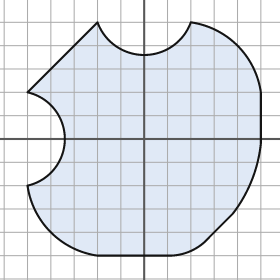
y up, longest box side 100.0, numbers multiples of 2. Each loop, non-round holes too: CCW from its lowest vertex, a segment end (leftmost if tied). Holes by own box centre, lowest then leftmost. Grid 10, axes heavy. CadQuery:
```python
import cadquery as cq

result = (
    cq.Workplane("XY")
    .moveTo(-20.0, -50.0)
    .lineTo(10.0, -50.0)
    .threePointArc((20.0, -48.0), (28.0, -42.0))
    .lineTo(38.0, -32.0)
    .threePointArc((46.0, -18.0), (50.0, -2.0))
    .lineTo(50.0, 20.0)
    .threePointArc((40.0, 40.0), (20.0, 50.0))
    .threePointArc((0.0, 36.0), (-20.0, 50.0))
    .lineTo(-50.0, 20.0)
    .threePointArc((-34.0, 0.0), (-50.0, -20.0))
    .threePointArc((-40.0, -40.0), (-20.0, -50.0))
    .close()
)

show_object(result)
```